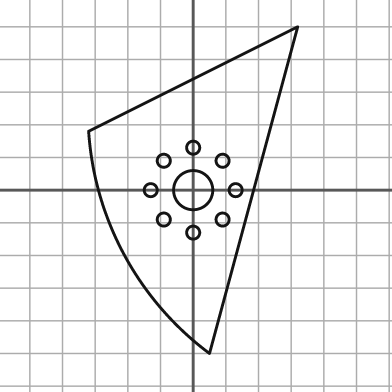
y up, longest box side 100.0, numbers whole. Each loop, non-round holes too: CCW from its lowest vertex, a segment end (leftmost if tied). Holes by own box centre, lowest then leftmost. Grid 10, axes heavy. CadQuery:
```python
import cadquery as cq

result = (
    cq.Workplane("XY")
    .moveTo(5.0, -50.0)
    .lineTo(32.0, 50.0)
    .lineTo(-32.0, 18.0)
    .threePointArc((-21.0, -20.0), (5.0, -50.0))
    .close()
    .moveTo(0.0, -13.0)
    .circle(2.0)
    .moveTo(-9.0, -9.0)
    .circle(2.0)
    .moveTo(9.0, -9.0)
    .circle(2.0)
    .moveTo(-13.0, 0.0)
    .circle(2.0)
    .moveTo(0.0, 0.0)
    .circle(6.0)
    .moveTo(13.0, 0.0)
    .circle(2.0)
    .moveTo(-9.0, 9.0)
    .circle(2.0)
    .moveTo(9.0, 9.0)
    .circle(2.0)
    .moveTo(0.0, 13.0)
    .circle(2.0)
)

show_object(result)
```